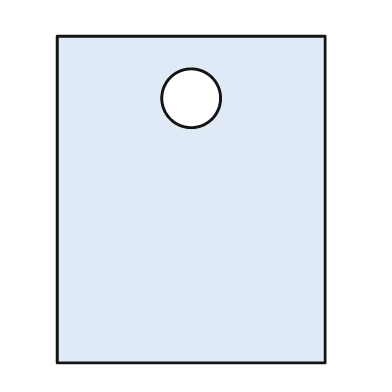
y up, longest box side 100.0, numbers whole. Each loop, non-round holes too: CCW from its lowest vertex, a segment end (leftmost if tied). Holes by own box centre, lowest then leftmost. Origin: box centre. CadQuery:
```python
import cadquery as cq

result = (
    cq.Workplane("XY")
    .moveTo(-41.0, -50.0)
    .lineTo(41.0, -50.0)
    .lineTo(41.0, 50.0)
    .lineTo(-41.0, 50.0)
    .close()
    .moveTo(0.0, 31.0)
    .circle(9.0)
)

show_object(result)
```